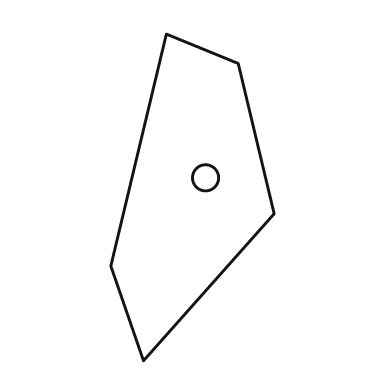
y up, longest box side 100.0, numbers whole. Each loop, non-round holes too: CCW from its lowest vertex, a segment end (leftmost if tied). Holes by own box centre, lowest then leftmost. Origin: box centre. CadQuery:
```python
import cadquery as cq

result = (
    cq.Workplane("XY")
    .moveTo(-15.0, -50.0)
    .lineTo(25.0, -5.0)
    .lineTo(14.0, 41.0)
    .lineTo(-8.0, 50.0)
    .lineTo(-25.0, -21.0)
    .close()
    .moveTo(4.0, 6.0)
    .circle(4.0)
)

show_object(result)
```